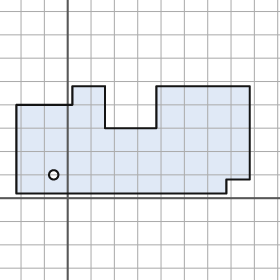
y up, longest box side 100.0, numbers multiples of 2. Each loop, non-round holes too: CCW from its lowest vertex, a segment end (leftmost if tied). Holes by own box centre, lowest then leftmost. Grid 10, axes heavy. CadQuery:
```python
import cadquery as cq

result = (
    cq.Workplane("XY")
    .moveTo(-22.0, 2.0)
    .lineTo(68.0, 2.0)
    .lineTo(68.0, 8.0)
    .lineTo(78.0, 8.0)
    .lineTo(78.0, 48.0)
    .lineTo(38.0, 48.0)
    .lineTo(38.0, 30.0)
    .lineTo(16.0, 30.0)
    .lineTo(16.0, 48.0)
    .lineTo(2.0, 48.0)
    .lineTo(2.0, 40.0)
    .lineTo(-22.0, 40.0)
    .close()
    .moveTo(-6.0, 10.0)
    .circle(2.0)
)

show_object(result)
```